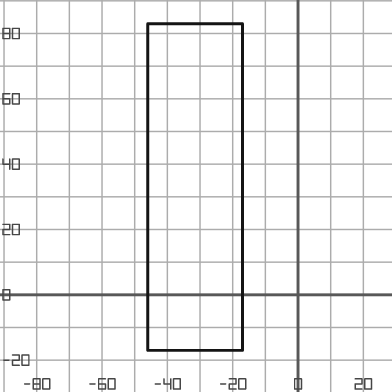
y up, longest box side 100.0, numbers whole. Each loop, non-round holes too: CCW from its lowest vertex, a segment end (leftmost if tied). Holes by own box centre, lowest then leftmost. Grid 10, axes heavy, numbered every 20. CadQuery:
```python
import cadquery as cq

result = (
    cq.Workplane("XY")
    .moveTo(-46.0, -17.0)
    .lineTo(-17.0, -17.0)
    .lineTo(-17.0, 83.0)
    .lineTo(-46.0, 83.0)
    .close()
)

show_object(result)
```